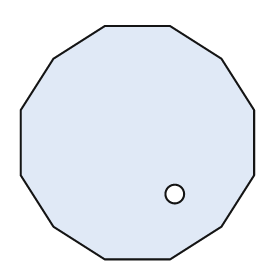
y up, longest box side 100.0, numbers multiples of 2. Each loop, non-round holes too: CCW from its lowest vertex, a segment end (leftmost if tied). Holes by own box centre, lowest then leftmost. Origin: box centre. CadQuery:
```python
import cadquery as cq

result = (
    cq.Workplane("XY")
    .moveTo(-14.0, -50.0)
    .lineTo(14.0, -50.0)
    .lineTo(36.0, -36.0)
    .lineTo(50.0, -14.0)
    .lineTo(50.0, 14.0)
    .lineTo(36.0, 36.0)
    .lineTo(14.0, 50.0)
    .lineTo(-14.0, 50.0)
    .lineTo(-36.0, 36.0)
    .lineTo(-50.0, 14.0)
    .lineTo(-50.0, -14.0)
    .lineTo(-36.0, -36.0)
    .close()
    .moveTo(16.0, -22.0)
    .circle(4.0)
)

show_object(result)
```